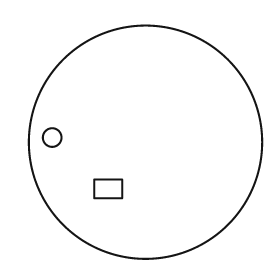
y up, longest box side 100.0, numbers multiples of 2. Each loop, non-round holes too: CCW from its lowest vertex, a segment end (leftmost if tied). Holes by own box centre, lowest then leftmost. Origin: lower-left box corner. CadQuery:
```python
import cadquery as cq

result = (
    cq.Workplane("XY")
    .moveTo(50.0, 50.0)
    .circle(50.0)
    .moveTo(28.0, 26.0)
    .lineTo(40.0, 26.0)
    .lineTo(40.0, 34.0)
    .lineTo(28.0, 34.0)
    .close()
    .moveTo(10.0, 52.0)
    .circle(4.0)
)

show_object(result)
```